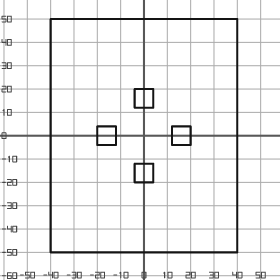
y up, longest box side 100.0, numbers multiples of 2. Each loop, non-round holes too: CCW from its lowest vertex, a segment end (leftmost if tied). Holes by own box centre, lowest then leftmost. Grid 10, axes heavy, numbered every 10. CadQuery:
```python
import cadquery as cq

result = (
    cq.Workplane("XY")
    .moveTo(-40.0, -50.0)
    .lineTo(40.0, -50.0)
    .lineTo(40.0, 50.0)
    .lineTo(-40.0, 50.0)
    .close()
    .moveTo(-4.0, -20.0)
    .lineTo(4.0, -20.0)
    .lineTo(4.0, -12.0)
    .lineTo(-4.0, -12.0)
    .close()
    .moveTo(-20.0, -4.0)
    .lineTo(-12.0, -4.0)
    .lineTo(-12.0, 4.0)
    .lineTo(-20.0, 4.0)
    .close()
    .moveTo(12.0, -4.0)
    .lineTo(20.0, -4.0)
    .lineTo(20.0, 4.0)
    .lineTo(12.0, 4.0)
    .close()
    .moveTo(-4.0, 12.0)
    .lineTo(4.0, 12.0)
    .lineTo(4.0, 20.0)
    .lineTo(-4.0, 20.0)
    .close()
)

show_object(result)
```